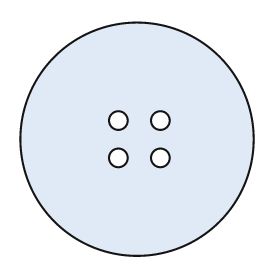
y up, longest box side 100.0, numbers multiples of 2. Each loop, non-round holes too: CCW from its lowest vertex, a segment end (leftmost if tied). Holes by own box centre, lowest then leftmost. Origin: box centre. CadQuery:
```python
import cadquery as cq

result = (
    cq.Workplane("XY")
    .moveTo(0.0, 0.0)
    .circle(50.0)
    .moveTo(-8.0, -8.0)
    .circle(4.0)
    .moveTo(10.0, -8.0)
    .circle(4.0)
    .moveTo(-8.0, 8.0)
    .circle(4.0)
    .moveTo(10.0, 8.0)
    .circle(4.0)
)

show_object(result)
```